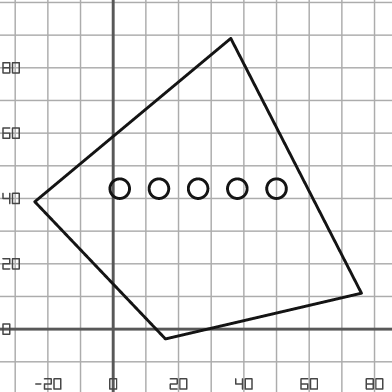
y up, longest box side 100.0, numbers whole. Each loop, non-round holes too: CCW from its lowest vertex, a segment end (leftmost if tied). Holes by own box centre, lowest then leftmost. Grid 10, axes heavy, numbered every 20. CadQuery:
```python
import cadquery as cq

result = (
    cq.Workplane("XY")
    .moveTo(16.0, -3.0)
    .lineTo(76.0, 11.0)
    .lineTo(36.0, 89.0)
    .lineTo(-24.0, 39.0)
    .close()
    .moveTo(2.0, 43.0)
    .circle(3.0)
    .moveTo(14.0, 43.0)
    .circle(3.0)
    .moveTo(26.0, 43.0)
    .circle(3.0)
    .moveTo(38.0, 43.0)
    .circle(3.0)
    .moveTo(50.0, 43.0)
    .circle(3.0)
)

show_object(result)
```